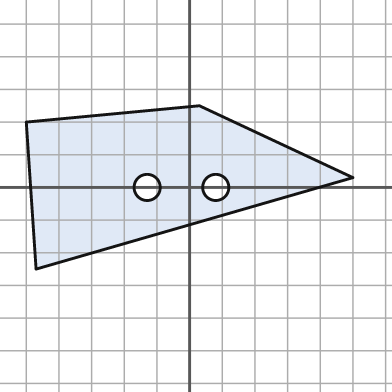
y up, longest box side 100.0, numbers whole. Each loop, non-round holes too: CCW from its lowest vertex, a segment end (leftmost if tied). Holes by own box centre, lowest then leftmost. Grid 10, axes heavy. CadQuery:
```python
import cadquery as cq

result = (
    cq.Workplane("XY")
    .moveTo(-47.0, -25.0)
    .lineTo(50.0, 3.0)
    .lineTo(3.0, 25.0)
    .lineTo(-50.0, 20.0)
    .close()
    .moveTo(-13.0, 0.0)
    .circle(4.0)
    .moveTo(8.0, 0.0)
    .circle(4.0)
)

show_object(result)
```